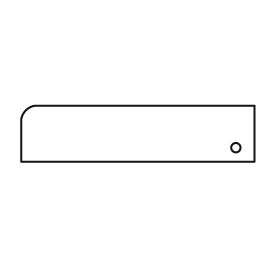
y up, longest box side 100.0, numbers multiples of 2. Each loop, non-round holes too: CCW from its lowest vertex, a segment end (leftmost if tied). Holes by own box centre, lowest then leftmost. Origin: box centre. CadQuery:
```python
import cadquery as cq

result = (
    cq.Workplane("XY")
    .moveTo(-50.0, -12.0)
    .lineTo(50.0, -12.0)
    .lineTo(50.0, 12.0)
    .lineTo(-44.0, 12.0)
    .threePointArc((-48.0, 10.0), (-50.0, 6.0))
    .close()
    .moveTo(42.0, -6.0)
    .circle(2.0)
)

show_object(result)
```